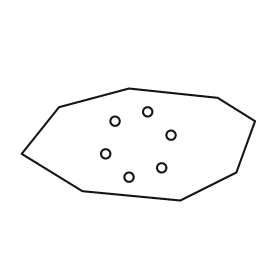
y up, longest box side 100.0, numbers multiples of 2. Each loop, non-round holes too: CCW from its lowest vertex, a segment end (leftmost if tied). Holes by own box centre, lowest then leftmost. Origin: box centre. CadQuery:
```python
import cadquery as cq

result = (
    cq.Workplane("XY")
    .moveTo(18.0, -24.0)
    .lineTo(42.0, -12.0)
    .lineTo(50.0, 10.0)
    .lineTo(34.0, 20.0)
    .lineTo(-4.0, 24.0)
    .lineTo(-34.0, 16.0)
    .lineTo(-50.0, -4.0)
    .lineTo(-24.0, -20.0)
    .close()
    .moveTo(-4.0, -14.0)
    .circle(2.0)
    .moveTo(10.0, -10.0)
    .circle(2.0)
    .moveTo(-14.0, -4.0)
    .circle(2.0)
    .moveTo(14.0, 4.0)
    .circle(2.0)
    .moveTo(-10.0, 10.0)
    .circle(2.0)
    .moveTo(4.0, 14.0)
    .circle(2.0)
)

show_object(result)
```